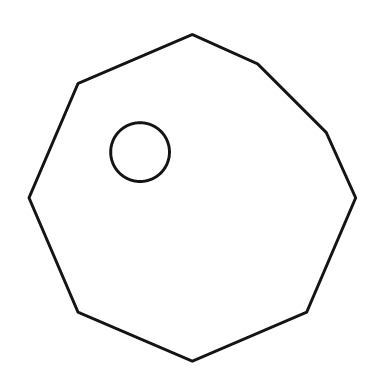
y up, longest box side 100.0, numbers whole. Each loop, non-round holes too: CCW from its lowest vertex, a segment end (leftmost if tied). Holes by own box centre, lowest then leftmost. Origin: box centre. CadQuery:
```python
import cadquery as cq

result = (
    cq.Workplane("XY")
    .moveTo(0.0, -50.0)
    .lineTo(35.0, -35.0)
    .lineTo(50.0, 0.0)
    .lineTo(41.0, 20.0)
    .lineTo(20.0, 41.0)
    .lineTo(0.0, 50.0)
    .lineTo(-35.0, 35.0)
    .lineTo(-50.0, 0.0)
    .lineTo(-35.0, -35.0)
    .close()
    .moveTo(-16.0, 14.0)
    .circle(9.0)
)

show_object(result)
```